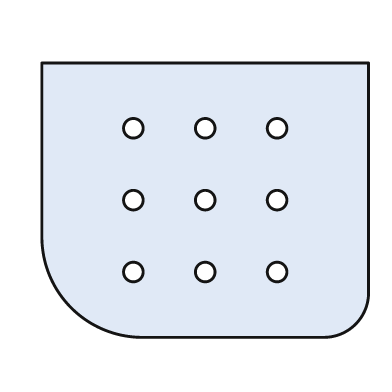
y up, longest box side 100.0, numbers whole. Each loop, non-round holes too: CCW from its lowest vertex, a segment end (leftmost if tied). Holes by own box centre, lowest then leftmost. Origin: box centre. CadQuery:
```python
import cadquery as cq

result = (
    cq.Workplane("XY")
    .moveTo(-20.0, -42.0)
    .lineTo(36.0, -42.0)
    .threePointArc((46.0, -38.0), (50.0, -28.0))
    .lineTo(50.0, 42.0)
    .lineTo(-50.0, 42.0)
    .lineTo(-50.0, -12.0)
    .threePointArc((-41.0, -33.0), (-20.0, -42.0))
    .close()
    .moveTo(-22.0, -22.0)
    .circle(3.0)
    .moveTo(0.0, -22.0)
    .circle(3.0)
    .moveTo(22.0, -22.0)
    .circle(3.0)
    .moveTo(-22.0, 0.0)
    .circle(3.0)
    .moveTo(0.0, 0.0)
    .circle(3.0)
    .moveTo(22.0, 0.0)
    .circle(3.0)
    .moveTo(-22.0, 22.0)
    .circle(3.0)
    .moveTo(0.0, 22.0)
    .circle(3.0)
    .moveTo(22.0, 22.0)
    .circle(3.0)
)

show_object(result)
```